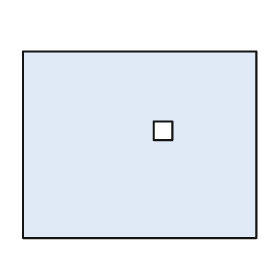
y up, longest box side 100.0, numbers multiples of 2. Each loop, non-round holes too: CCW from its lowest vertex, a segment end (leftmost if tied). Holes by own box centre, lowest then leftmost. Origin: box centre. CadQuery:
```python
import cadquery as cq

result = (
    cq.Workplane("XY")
    .moveTo(-50.0, -40.0)
    .lineTo(50.0, -40.0)
    .lineTo(50.0, 40.0)
    .lineTo(-50.0, 40.0)
    .close()
    .moveTo(6.0, 2.0)
    .lineTo(14.0, 2.0)
    .lineTo(14.0, 10.0)
    .lineTo(6.0, 10.0)
    .close()
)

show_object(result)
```